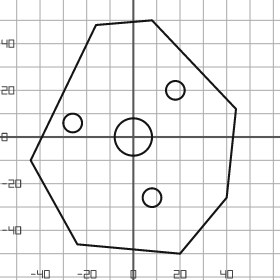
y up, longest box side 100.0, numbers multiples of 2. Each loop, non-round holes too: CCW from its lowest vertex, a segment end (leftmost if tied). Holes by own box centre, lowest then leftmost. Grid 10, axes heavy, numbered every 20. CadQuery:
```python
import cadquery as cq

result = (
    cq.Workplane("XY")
    .moveTo(20.0, -50.0)
    .lineTo(40.0, -26.0)
    .lineTo(44.0, 12.0)
    .lineTo(8.0, 50.0)
    .lineTo(-16.0, 48.0)
    .lineTo(-44.0, -10.0)
    .lineTo(-24.0, -46.0)
    .close()
    .moveTo(8.0, -26.0)
    .circle(4.0)
    .moveTo(0.0, 0.0)
    .circle(8.0)
    .moveTo(-26.0, 6.0)
    .circle(4.0)
    .moveTo(18.0, 20.0)
    .circle(4.0)
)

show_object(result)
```